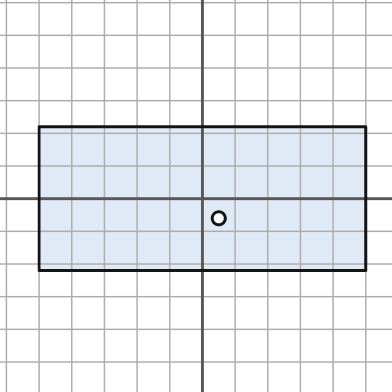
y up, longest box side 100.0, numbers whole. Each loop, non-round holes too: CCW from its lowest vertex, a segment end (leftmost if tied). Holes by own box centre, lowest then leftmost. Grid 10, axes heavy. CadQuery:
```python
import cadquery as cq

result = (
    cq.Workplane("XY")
    .moveTo(-50.0, -22.0)
    .lineTo(50.0, -22.0)
    .lineTo(50.0, 22.0)
    .lineTo(-50.0, 22.0)
    .close()
    .moveTo(5.0, -6.0)
    .circle(2.0)
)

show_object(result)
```